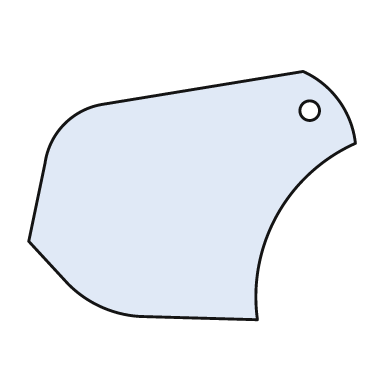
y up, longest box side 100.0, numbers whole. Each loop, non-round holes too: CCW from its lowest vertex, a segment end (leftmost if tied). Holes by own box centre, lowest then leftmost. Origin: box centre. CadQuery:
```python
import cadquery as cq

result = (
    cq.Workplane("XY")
    .moveTo(20.0, -38.0)
    .threePointArc((26.0, -6.0), (50.0, 16.0))
    .threePointArc((45.0, 29.0), (34.0, 38.0))
    .lineTo(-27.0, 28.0)
    .threePointArc((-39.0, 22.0), (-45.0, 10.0))
    .lineTo(-50.0, -14.0)
    .lineTo(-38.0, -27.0)
    .threePointArc((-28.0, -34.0), (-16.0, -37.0))
    .close()
    .moveTo(36.0, 26.0)
    .circle(3.0)
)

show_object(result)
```